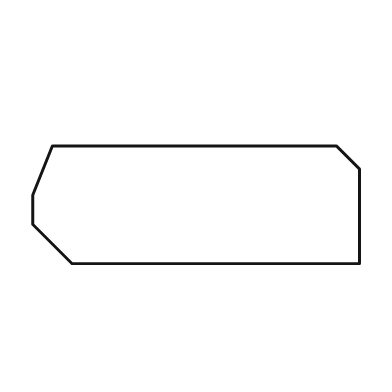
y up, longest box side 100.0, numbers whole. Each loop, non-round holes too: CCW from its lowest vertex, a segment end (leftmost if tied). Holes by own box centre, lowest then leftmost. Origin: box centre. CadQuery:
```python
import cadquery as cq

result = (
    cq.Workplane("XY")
    .moveTo(-38.0, -18.0)
    .lineTo(50.0, -18.0)
    .lineTo(50.0, 11.0)
    .lineTo(43.0, 18.0)
    .lineTo(-44.0, 18.0)
    .lineTo(-50.0, 3.0)
    .lineTo(-50.0, -6.0)
    .close()
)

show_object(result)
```